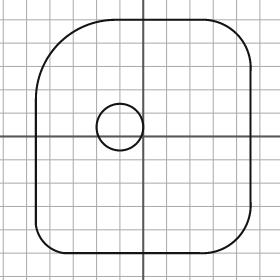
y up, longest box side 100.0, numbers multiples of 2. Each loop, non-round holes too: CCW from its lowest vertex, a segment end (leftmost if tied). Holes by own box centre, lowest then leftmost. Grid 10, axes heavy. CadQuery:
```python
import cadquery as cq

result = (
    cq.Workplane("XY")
    .moveTo(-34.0, -50.0)
    .lineTo(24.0, -50.0)
    .threePointArc((40.0, -44.0), (46.0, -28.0))
    .lineTo(46.0, 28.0)
    .threePointArc((40.0, 44.0), (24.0, 50.0))
    .lineTo(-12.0, 50.0)
    .threePointArc((-36.0, 40.0), (-46.0, 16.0))
    .lineTo(-46.0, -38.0)
    .threePointArc((-42.0, -46.0), (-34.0, -50.0))
    .close()
    .moveTo(-10.0, 4.0)
    .circle(10.0)
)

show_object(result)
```